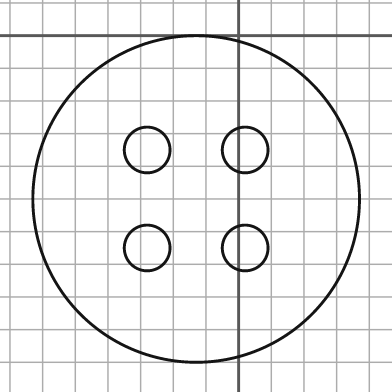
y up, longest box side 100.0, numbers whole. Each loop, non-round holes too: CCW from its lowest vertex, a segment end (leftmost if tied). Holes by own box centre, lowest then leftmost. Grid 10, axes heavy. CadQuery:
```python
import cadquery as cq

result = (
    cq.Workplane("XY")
    .moveTo(-13.0, -50.0)
    .circle(50.0)
    .moveTo(-28.0, -65.0)
    .circle(7.0)
    .moveTo(2.0, -65.0)
    .circle(7.0)
    .moveTo(-28.0, -35.0)
    .circle(7.0)
    .moveTo(2.0, -35.0)
    .circle(7.0)
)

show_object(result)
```